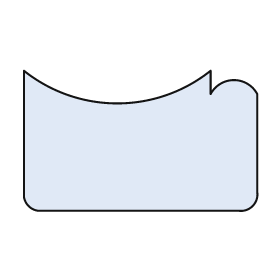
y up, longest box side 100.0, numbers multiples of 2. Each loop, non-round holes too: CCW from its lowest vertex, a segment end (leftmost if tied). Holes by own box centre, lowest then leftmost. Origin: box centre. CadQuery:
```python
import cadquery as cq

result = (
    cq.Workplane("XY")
    .moveTo(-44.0, -30.0)
    .lineTo(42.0, -30.0)
    .threePointArc((48.0, -28.0), (50.0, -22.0))
    .lineTo(50.0, 20.0)
    .threePointArc((40.0, 26.0), (30.0, 20.0))
    .lineTo(30.0, 30.0)
    .threePointArc((-10.0, 16.0), (-50.0, 30.0))
    .lineTo(-50.0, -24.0)
    .threePointArc((-48.0, -28.0), (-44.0, -30.0))
    .close()
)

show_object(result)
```